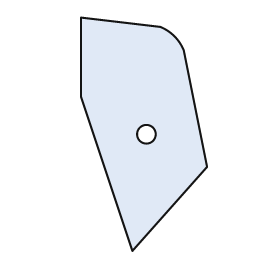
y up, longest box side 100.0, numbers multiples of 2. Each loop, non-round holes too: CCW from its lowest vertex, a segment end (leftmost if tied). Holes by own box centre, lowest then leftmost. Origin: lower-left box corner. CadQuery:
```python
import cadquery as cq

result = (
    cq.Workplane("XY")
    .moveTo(22.0, 0.0)
    .lineTo(54.0, 36.0)
    .lineTo(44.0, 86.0)
    .threePointArc((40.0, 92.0), (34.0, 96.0))
    .lineTo(0.0, 100.0)
    .lineTo(0.0, 66.0)
    .close()
    .moveTo(28.0, 50.0)
    .circle(4.0)
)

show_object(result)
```